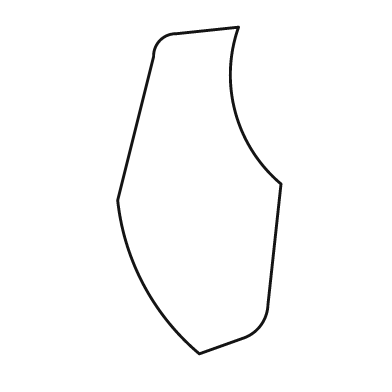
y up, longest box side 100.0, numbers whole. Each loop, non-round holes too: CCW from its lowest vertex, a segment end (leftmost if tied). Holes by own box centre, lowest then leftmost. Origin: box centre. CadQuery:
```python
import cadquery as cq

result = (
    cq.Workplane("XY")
    .moveTo(0.0, -50.0)
    .lineTo(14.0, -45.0)
    .threePointArc((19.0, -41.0), (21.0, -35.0))
    .lineTo(25.0, 2.0)
    .threePointArc((11.0, 24.0), (12.0, 50.0))
    .lineTo(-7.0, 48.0)
    .threePointArc((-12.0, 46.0), (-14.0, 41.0))
    .lineTo(-25.0, -3.0)
    .threePointArc((-17.0, -29.0), (0.0, -50.0))
    .close()
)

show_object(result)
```